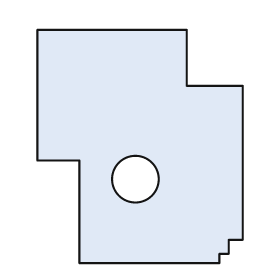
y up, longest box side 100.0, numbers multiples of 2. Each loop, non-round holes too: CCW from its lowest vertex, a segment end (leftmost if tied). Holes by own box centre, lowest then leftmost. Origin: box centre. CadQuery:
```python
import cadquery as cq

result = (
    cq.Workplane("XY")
    .moveTo(-26.0, -50.0)
    .lineTo(34.0, -50.0)
    .lineTo(34.0, -46.0)
    .lineTo(38.0, -46.0)
    .lineTo(38.0, -40.0)
    .lineTo(44.0, -40.0)
    .lineTo(44.0, 26.0)
    .lineTo(20.0, 26.0)
    .lineTo(20.0, 50.0)
    .lineTo(-44.0, 50.0)
    .lineTo(-44.0, -6.0)
    .lineTo(-26.0, -6.0)
    .close()
    .moveTo(-2.0, -14.0)
    .circle(10.0)
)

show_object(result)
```